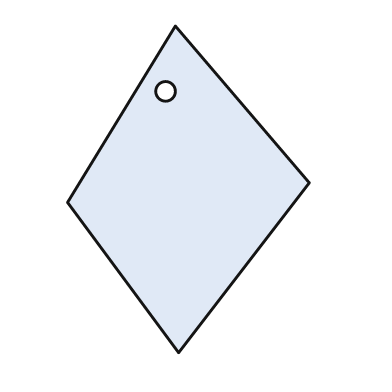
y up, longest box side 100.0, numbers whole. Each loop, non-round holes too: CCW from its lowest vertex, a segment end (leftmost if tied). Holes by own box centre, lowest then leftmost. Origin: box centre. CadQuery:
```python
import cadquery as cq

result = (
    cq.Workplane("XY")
    .moveTo(-3.0, -50.0)
    .lineTo(37.0, 2.0)
    .lineTo(-4.0, 50.0)
    .lineTo(-37.0, -4.0)
    .close()
    .moveTo(-7.0, 30.0)
    .circle(3.0)
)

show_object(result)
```